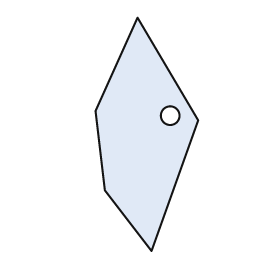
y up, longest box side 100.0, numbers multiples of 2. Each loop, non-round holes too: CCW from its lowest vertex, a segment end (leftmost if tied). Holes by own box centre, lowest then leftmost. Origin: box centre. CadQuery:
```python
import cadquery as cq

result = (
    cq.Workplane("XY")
    .moveTo(2.0, -50.0)
    .lineTo(22.0, 6.0)
    .lineTo(-4.0, 50.0)
    .lineTo(-22.0, 10.0)
    .lineTo(-18.0, -24.0)
    .close()
    .moveTo(10.0, 8.0)
    .circle(4.0)
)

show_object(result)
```